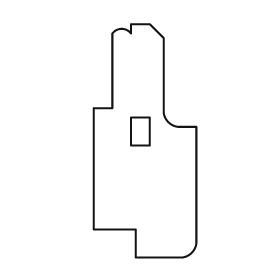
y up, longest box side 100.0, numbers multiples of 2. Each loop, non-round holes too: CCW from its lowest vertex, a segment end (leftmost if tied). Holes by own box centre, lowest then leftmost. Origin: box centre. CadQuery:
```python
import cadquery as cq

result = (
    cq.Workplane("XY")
    .moveTo(-4.0, -50.0)
    .lineTo(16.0, -50.0)
    .threePointArc((20.0, -48.0), (22.0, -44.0))
    .lineTo(22.0, 6.0)
    .lineTo(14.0, 6.0)
    .threePointArc((10.0, 8.0), (8.0, 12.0))
    .lineTo(8.0, 44.0)
    .lineTo(2.0, 50.0)
    .lineTo(-6.0, 50.0)
    .lineTo(-6.0, 46.0)
    .threePointArc((-10.0, 48.0), (-14.0, 46.0))
    .lineTo(-14.0, 14.0)
    .lineTo(-22.0, 14.0)
    .lineTo(-22.0, -38.0)
    .lineTo(-4.0, -38.0)
    .close()
    .moveTo(-6.0, -2.0)
    .lineTo(2.0, -2.0)
    .lineTo(2.0, 10.0)
    .lineTo(-6.0, 10.0)
    .close()
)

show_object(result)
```